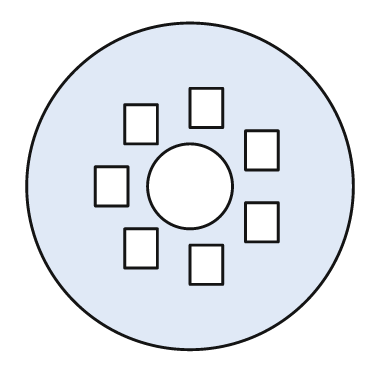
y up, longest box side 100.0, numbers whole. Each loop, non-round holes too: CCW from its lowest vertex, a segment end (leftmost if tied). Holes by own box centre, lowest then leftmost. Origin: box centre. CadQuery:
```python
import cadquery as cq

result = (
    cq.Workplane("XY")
    .moveTo(0.0, 0.0)
    .circle(50.0)
    .moveTo(0.0, -30.0)
    .lineTo(10.0, -30.0)
    .lineTo(10.0, -18.0)
    .lineTo(0.0, -18.0)
    .close()
    .moveTo(-20.0, -25.0)
    .lineTo(-10.0, -25.0)
    .lineTo(-10.0, -13.0)
    .lineTo(-20.0, -13.0)
    .close()
    .moveTo(17.0, -17.0)
    .lineTo(27.0, -17.0)
    .lineTo(27.0, -5.0)
    .lineTo(17.0, -5.0)
    .close()
    .moveTo(-29.0, -6.0)
    .lineTo(-19.0, -6.0)
    .lineTo(-19.0, 6.0)
    .lineTo(-29.0, 6.0)
    .close()
    .moveTo(0.0, 0.0)
    .circle(13.0)
    .moveTo(17.0, 5.0)
    .lineTo(27.0, 5.0)
    .lineTo(27.0, 17.0)
    .lineTo(17.0, 17.0)
    .close()
    .moveTo(-20.0, 13.0)
    .lineTo(-10.0, 13.0)
    .lineTo(-10.0, 25.0)
    .lineTo(-20.0, 25.0)
    .close()
    .moveTo(0.0, 18.0)
    .lineTo(10.0, 18.0)
    .lineTo(10.0, 30.0)
    .lineTo(0.0, 30.0)
    .close()
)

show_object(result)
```